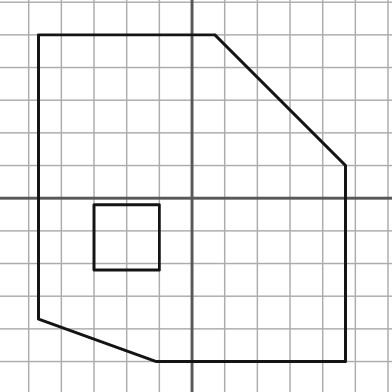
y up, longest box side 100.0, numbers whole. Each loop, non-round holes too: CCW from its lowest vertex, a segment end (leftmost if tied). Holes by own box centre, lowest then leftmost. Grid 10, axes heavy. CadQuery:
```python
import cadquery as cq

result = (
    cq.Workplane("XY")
    .moveTo(-11.0, -50.0)
    .lineTo(47.0, -50.0)
    .lineTo(47.0, 10.0)
    .lineTo(7.0, 50.0)
    .lineTo(-47.0, 50.0)
    .lineTo(-47.0, -37.0)
    .close()
    .moveTo(-30.0, -22.0)
    .lineTo(-10.0, -22.0)
    .lineTo(-10.0, -2.0)
    .lineTo(-30.0, -2.0)
    .close()
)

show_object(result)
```